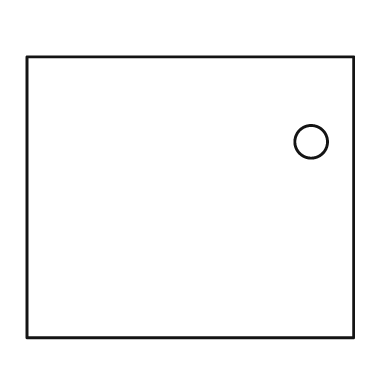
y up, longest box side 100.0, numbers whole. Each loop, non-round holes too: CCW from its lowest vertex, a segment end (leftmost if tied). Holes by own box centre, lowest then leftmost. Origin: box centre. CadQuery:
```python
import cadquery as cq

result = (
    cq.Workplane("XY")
    .moveTo(-50.0, -43.0)
    .lineTo(50.0, -43.0)
    .lineTo(50.0, 43.0)
    .lineTo(-50.0, 43.0)
    .close()
    .moveTo(37.0, 17.0)
    .circle(5.0)
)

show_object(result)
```